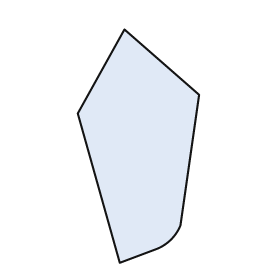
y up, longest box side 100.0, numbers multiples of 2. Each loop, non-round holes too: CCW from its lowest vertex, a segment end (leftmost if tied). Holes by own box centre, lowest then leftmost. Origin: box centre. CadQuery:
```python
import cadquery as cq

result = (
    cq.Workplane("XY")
    .moveTo(-8.0, -50.0)
    .lineTo(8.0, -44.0)
    .threePointArc((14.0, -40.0), (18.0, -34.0))
    .lineTo(26.0, 22.0)
    .lineTo(-6.0, 50.0)
    .lineTo(-26.0, 14.0)
    .close()
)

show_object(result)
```